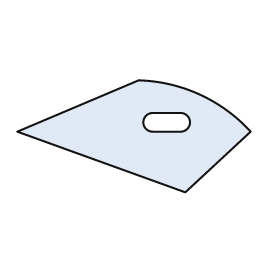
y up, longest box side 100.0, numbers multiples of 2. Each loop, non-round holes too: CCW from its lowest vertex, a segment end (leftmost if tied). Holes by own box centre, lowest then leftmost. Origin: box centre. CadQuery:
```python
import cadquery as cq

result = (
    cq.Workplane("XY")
    .moveTo(22.0, -24.0)
    .lineTo(50.0, 2.0)
    .threePointArc((28.0, 18.0), (2.0, 24.0))
    .lineTo(-50.0, 2.0)
    .close()
    .moveTo(8.0, 2.0)
    .lineTo(20.0, 2.0)
    .threePointArc((24.0, 6.0), (20.0, 10.0))
    .lineTo(8.0, 10.0)
    .threePointArc((4.0, 6.0), (8.0, 2.0))
    .close()
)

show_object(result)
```